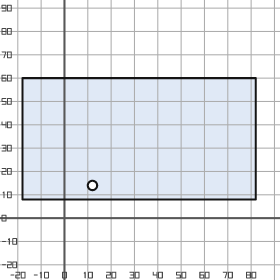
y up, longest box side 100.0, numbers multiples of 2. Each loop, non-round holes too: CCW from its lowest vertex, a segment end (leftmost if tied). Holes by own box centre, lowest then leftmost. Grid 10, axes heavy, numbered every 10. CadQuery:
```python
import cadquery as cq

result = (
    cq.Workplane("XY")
    .moveTo(-18.0, 8.0)
    .lineTo(82.0, 8.0)
    .lineTo(82.0, 60.0)
    .lineTo(-18.0, 60.0)
    .close()
    .moveTo(12.0, 14.0)
    .circle(2.0)
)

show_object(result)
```